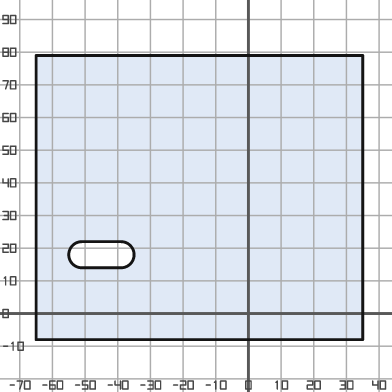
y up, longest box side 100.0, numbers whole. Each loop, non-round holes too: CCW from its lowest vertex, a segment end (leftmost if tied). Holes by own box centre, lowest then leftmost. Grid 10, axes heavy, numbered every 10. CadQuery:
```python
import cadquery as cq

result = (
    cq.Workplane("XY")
    .moveTo(-65.0, -8.0)
    .lineTo(35.0, -8.0)
    .lineTo(35.0, 79.0)
    .lineTo(-65.0, 79.0)
    .close()
    .moveTo(-51.0, 14.0)
    .lineTo(-39.0, 14.0)
    .threePointArc((-35.0, 18.0), (-39.0, 22.0))
    .lineTo(-51.0, 22.0)
    .threePointArc((-55.0, 18.0), (-51.0, 14.0))
    .close()
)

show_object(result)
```